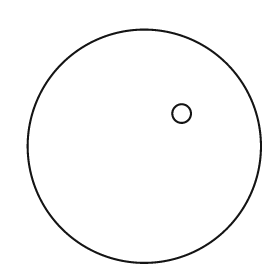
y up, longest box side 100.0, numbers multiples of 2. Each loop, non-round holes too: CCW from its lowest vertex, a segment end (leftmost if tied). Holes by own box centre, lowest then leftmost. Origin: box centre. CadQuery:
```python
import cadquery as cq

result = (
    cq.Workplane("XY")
    .moveTo(0.0, 0.0)
    .circle(50.0)
    .moveTo(16.0, 14.0)
    .circle(4.0)
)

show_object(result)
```